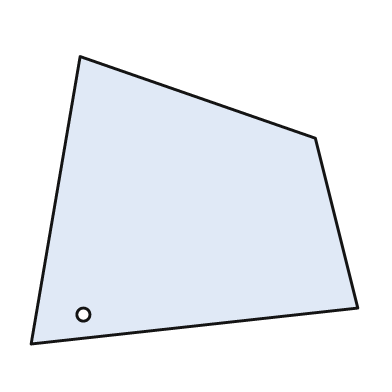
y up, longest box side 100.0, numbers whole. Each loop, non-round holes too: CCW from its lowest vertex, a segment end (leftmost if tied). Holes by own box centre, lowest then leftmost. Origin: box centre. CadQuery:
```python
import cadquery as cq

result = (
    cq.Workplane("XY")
    .moveTo(-50.0, -44.0)
    .lineTo(50.0, -33.0)
    .lineTo(37.0, 19.0)
    .lineTo(-35.0, 44.0)
    .close()
    .moveTo(-34.0, -35.0)
    .circle(2.0)
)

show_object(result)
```